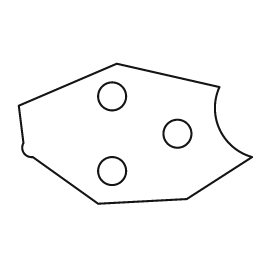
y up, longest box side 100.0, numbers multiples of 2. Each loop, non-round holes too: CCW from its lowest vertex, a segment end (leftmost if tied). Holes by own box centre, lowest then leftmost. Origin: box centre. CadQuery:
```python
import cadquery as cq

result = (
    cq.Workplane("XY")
    .moveTo(-16.0, -30.0)
    .lineTo(22.0, -28.0)
    .lineTo(50.0, -10.0)
    .threePointArc((36.0, 2.0), (36.0, 20.0))
    .lineTo(-8.0, 30.0)
    .lineTo(-50.0, 12.0)
    .lineTo(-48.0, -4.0)
    .threePointArc((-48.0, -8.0), (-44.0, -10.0))
    .close()
    .moveTo(-10.0, -16.0)
    .circle(6.0)
    .moveTo(18.0, 0.0)
    .circle(6.0)
    .moveTo(-10.0, 16.0)
    .circle(6.0)
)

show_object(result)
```